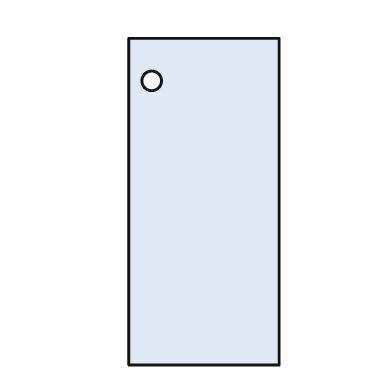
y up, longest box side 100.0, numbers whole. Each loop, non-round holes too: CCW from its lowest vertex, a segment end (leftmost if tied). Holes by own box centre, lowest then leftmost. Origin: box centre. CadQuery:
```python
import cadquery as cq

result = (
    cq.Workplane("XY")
    .moveTo(-23.0, -50.0)
    .lineTo(23.0, -50.0)
    .lineTo(23.0, 50.0)
    .lineTo(-23.0, 50.0)
    .close()
    .moveTo(-16.0, 37.0)
    .circle(3.0)
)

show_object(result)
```